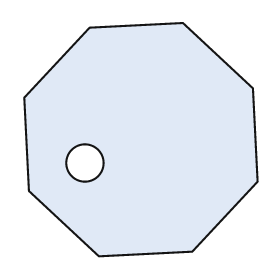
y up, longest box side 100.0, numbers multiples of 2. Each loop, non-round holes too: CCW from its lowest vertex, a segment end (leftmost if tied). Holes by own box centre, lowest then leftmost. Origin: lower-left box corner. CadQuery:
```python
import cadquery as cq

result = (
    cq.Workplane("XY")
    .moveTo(32.0, 0.0)
    .lineTo(72.0, 2.0)
    .lineTo(100.0, 32.0)
    .lineTo(98.0, 72.0)
    .lineTo(68.0, 100.0)
    .lineTo(28.0, 98.0)
    .lineTo(0.0, 68.0)
    .lineTo(2.0, 28.0)
    .close()
    .moveTo(26.0, 40.0)
    .circle(8.0)
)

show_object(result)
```